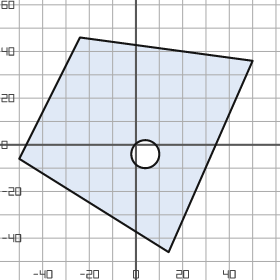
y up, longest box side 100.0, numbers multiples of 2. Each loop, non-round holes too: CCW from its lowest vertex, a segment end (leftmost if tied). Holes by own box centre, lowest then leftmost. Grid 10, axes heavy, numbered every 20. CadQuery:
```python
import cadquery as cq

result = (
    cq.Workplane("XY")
    .moveTo(14.0, -46.0)
    .lineTo(50.0, 36.0)
    .lineTo(-24.0, 46.0)
    .lineTo(-50.0, -6.0)
    .close()
    .moveTo(4.0, -4.0)
    .circle(6.0)
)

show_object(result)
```